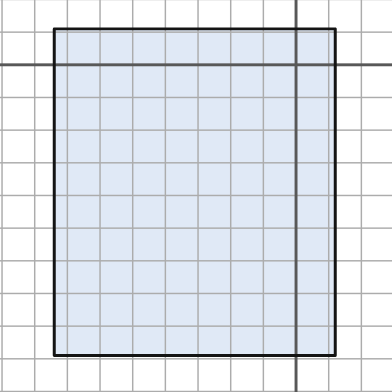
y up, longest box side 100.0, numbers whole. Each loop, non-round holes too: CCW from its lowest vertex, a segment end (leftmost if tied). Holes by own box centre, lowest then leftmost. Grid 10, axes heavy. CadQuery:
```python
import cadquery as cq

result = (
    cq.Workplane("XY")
    .moveTo(-74.0, -89.0)
    .lineTo(12.0, -89.0)
    .lineTo(12.0, 11.0)
    .lineTo(-74.0, 11.0)
    .close()
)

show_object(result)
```